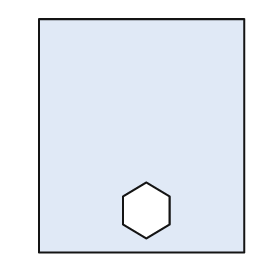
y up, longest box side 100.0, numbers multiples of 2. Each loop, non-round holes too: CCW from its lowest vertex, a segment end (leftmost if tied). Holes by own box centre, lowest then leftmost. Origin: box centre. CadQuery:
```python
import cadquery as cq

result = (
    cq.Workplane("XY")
    .moveTo(-44.0, -50.0)
    .lineTo(44.0, -50.0)
    .lineTo(44.0, 50.0)
    .lineTo(-44.0, 50.0)
    .close()
    .moveTo(2.0, -44.0)
    .lineTo(12.0, -38.0)
    .lineTo(12.0, -26.0)
    .lineTo(2.0, -20.0)
    .lineTo(-8.0, -26.0)
    .lineTo(-8.0, -38.0)
    .close()
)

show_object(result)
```